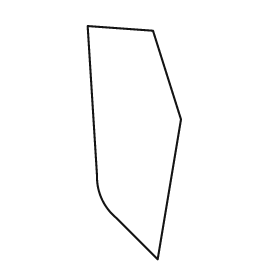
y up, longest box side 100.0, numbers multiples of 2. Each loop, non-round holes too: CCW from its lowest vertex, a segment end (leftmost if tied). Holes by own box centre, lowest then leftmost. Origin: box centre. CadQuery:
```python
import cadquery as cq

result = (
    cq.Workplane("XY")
    .moveTo(10.0, -50.0)
    .lineTo(20.0, 10.0)
    .lineTo(8.0, 48.0)
    .lineTo(-20.0, 50.0)
    .lineTo(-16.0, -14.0)
    .threePointArc((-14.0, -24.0), (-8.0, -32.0))
    .close()
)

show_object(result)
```